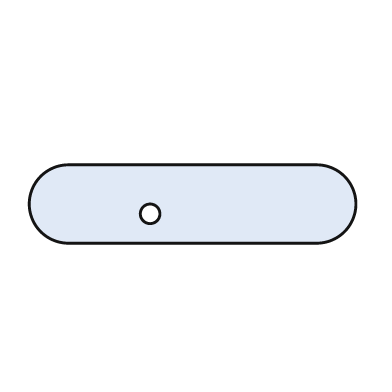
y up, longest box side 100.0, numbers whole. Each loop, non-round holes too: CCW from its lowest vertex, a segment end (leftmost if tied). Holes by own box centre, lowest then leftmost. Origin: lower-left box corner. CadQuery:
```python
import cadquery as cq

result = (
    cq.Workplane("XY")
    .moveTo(12.0, 0.0)
    .lineTo(88.0, 0.0)
    .threePointArc((100.0, 12.0), (88.0, 24.0))
    .lineTo(12.0, 24.0)
    .threePointArc((0.0, 12.0), (12.0, 0.0))
    .close()
    .moveTo(37.0, 9.0)
    .circle(3.0)
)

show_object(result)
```